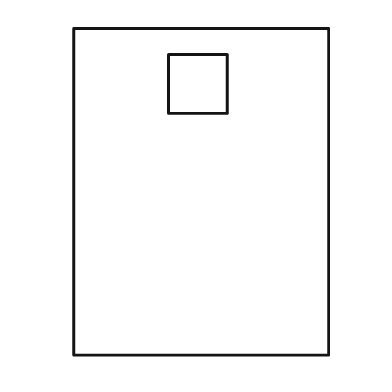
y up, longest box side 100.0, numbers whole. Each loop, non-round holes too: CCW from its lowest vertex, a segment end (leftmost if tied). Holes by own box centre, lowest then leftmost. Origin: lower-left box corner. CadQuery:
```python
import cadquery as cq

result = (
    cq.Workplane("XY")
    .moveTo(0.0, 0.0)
    .lineTo(78.0, 0.0)
    .lineTo(78.0, 100.0)
    .lineTo(0.0, 100.0)
    .close()
    .moveTo(29.0, 74.0)
    .lineTo(47.0, 74.0)
    .lineTo(47.0, 92.0)
    .lineTo(29.0, 92.0)
    .close()
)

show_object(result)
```